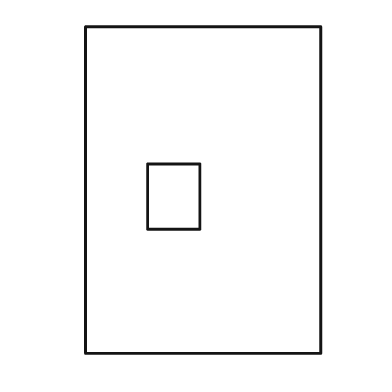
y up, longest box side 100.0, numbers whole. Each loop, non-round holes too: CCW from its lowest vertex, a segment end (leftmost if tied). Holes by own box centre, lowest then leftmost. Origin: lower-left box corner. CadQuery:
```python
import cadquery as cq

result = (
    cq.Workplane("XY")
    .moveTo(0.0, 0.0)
    .lineTo(72.0, 0.0)
    .lineTo(72.0, 100.0)
    .lineTo(0.0, 100.0)
    .close()
    .moveTo(19.0, 38.0)
    .lineTo(35.0, 38.0)
    .lineTo(35.0, 58.0)
    .lineTo(19.0, 58.0)
    .close()
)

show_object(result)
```